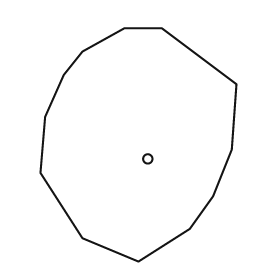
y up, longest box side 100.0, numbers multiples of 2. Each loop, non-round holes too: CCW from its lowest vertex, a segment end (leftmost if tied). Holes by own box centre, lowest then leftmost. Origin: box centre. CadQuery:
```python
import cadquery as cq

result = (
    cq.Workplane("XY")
    .moveTo(0.0, -50.0)
    .lineTo(22.0, -36.0)
    .lineTo(32.0, -22.0)
    .lineTo(40.0, -2.0)
    .lineTo(42.0, 26.0)
    .lineTo(10.0, 50.0)
    .lineTo(-6.0, 50.0)
    .lineTo(-24.0, 40.0)
    .lineTo(-32.0, 30.0)
    .lineTo(-40.0, 12.0)
    .lineTo(-42.0, -12.0)
    .lineTo(-24.0, -40.0)
    .close()
    .moveTo(4.0, -6.0)
    .circle(2.0)
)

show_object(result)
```